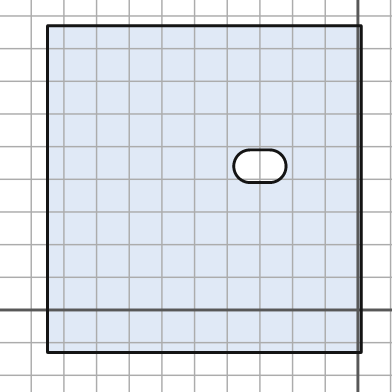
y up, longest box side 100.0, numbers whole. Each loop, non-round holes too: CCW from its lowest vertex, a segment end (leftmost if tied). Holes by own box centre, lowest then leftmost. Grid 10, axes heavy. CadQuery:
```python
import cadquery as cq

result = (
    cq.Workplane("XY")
    .moveTo(-95.0, -13.0)
    .lineTo(1.0, -13.0)
    .lineTo(1.0, 87.0)
    .lineTo(-95.0, 87.0)
    .close()
    .moveTo(-33.0, 39.0)
    .lineTo(-27.0, 39.0)
    .threePointArc((-22.0, 44.0), (-27.0, 49.0))
    .lineTo(-33.0, 49.0)
    .threePointArc((-38.0, 44.0), (-33.0, 39.0))
    .close()
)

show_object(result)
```